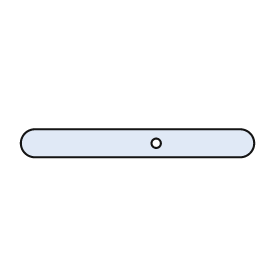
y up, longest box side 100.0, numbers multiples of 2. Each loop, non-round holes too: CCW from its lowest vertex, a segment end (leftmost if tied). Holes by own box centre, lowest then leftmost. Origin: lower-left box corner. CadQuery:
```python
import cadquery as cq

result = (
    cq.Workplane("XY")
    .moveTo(6.0, 0.0)
    .lineTo(94.0, 0.0)
    .threePointArc((100.0, 6.0), (94.0, 12.0))
    .lineTo(6.0, 12.0)
    .threePointArc((0.0, 6.0), (6.0, 0.0))
    .close()
    .moveTo(58.0, 6.0)
    .circle(2.0)
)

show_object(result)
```